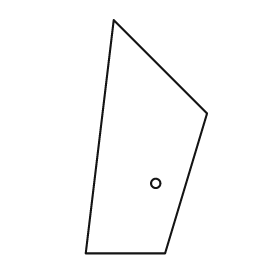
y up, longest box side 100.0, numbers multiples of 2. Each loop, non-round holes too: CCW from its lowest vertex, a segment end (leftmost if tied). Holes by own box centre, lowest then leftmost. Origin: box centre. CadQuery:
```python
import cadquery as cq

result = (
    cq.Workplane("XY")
    .moveTo(-26.0, -50.0)
    .lineTo(8.0, -50.0)
    .lineTo(26.0, 10.0)
    .lineTo(-14.0, 50.0)
    .close()
    .moveTo(4.0, -20.0)
    .circle(2.0)
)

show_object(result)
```